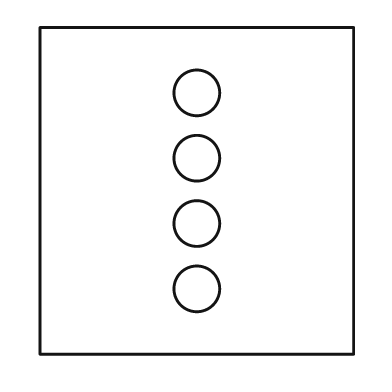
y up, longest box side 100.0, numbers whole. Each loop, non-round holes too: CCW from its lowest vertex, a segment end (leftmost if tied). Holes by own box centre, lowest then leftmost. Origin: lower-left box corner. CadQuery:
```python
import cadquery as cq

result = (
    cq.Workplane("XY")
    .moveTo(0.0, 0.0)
    .lineTo(96.0, 0.0)
    .lineTo(96.0, 100.0)
    .lineTo(0.0, 100.0)
    .close()
    .moveTo(48.0, 20.0)
    .circle(7.0)
    .moveTo(48.0, 40.0)
    .circle(7.0)
    .moveTo(48.0, 60.0)
    .circle(7.0)
    .moveTo(48.0, 80.0)
    .circle(7.0)
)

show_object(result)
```